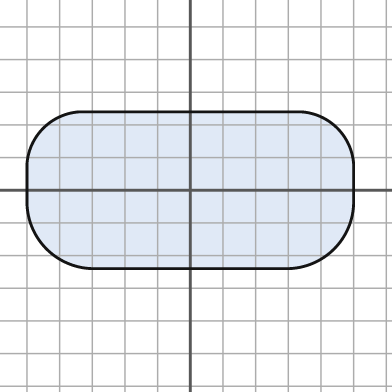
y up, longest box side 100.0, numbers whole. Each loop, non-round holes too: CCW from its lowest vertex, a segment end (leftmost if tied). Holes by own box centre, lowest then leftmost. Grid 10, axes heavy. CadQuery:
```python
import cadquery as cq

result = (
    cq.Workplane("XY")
    .moveTo(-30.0, -24.0)
    .lineTo(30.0, -24.0)
    .threePointArc((44.0, -18.0), (50.0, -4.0))
    .lineTo(50.0, 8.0)
    .threePointArc((45.0, 19.0), (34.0, 24.0))
    .lineTo(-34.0, 24.0)
    .threePointArc((-45.0, 19.0), (-50.0, 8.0))
    .lineTo(-50.0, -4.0)
    .threePointArc((-44.0, -18.0), (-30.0, -24.0))
    .close()
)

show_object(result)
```